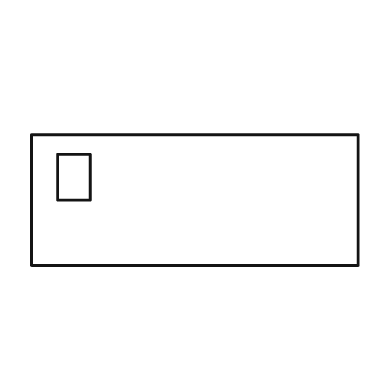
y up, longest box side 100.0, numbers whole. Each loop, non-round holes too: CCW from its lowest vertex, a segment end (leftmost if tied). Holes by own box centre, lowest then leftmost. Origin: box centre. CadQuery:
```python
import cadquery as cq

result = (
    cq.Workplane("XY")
    .moveTo(-50.0, -20.0)
    .lineTo(50.0, -20.0)
    .lineTo(50.0, 20.0)
    .lineTo(-50.0, 20.0)
    .close()
    .moveTo(-42.0, 0.0)
    .lineTo(-32.0, 0.0)
    .lineTo(-32.0, 14.0)
    .lineTo(-42.0, 14.0)
    .close()
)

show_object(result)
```